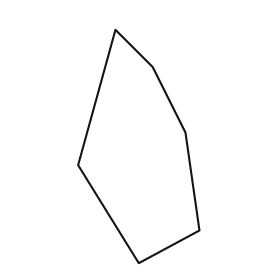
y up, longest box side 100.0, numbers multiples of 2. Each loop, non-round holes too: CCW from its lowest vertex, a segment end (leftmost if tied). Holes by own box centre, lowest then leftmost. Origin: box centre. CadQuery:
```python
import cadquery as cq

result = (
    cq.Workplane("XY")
    .moveTo(0.0, -50.0)
    .lineTo(26.0, -36.0)
    .lineTo(20.0, 6.0)
    .lineTo(6.0, 34.0)
    .lineTo(-10.0, 50.0)
    .lineTo(-26.0, -8.0)
    .close()
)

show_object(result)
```